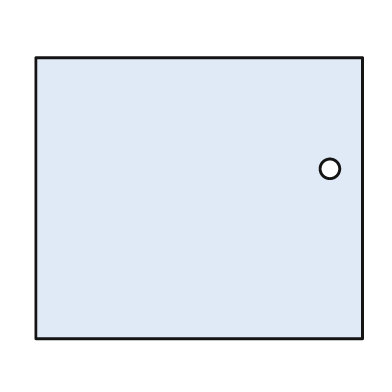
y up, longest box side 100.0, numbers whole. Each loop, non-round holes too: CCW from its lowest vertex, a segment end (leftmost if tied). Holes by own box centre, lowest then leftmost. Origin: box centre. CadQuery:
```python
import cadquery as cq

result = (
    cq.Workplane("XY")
    .moveTo(-50.0, -43.0)
    .lineTo(50.0, -43.0)
    .lineTo(50.0, 43.0)
    .lineTo(-50.0, 43.0)
    .close()
    .moveTo(40.0, 9.0)
    .circle(3.0)
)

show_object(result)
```